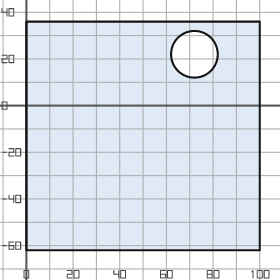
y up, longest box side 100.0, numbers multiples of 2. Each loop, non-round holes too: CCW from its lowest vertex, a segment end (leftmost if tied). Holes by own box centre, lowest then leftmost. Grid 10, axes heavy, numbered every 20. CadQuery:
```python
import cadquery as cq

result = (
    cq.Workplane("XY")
    .moveTo(0.0, -62.0)
    .lineTo(100.0, -62.0)
    .lineTo(100.0, 36.0)
    .lineTo(0.0, 36.0)
    .close()
    .moveTo(72.0, 22.0)
    .circle(10.0)
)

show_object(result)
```